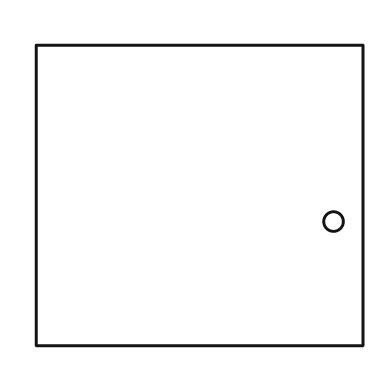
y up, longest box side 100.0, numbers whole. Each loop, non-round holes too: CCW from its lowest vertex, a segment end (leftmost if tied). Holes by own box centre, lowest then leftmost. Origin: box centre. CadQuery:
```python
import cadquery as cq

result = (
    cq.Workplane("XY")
    .moveTo(-50.0, -46.0)
    .lineTo(50.0, -46.0)
    .lineTo(50.0, 46.0)
    .lineTo(-50.0, 46.0)
    .close()
    .moveTo(41.0, -8.0)
    .circle(3.0)
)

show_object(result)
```